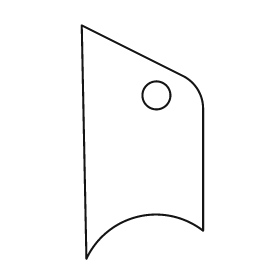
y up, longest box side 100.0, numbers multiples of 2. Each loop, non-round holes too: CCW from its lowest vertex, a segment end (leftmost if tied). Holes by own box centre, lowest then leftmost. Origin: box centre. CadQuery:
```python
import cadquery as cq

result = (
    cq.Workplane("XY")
    .moveTo(-24.0, -50.0)
    .threePointArc((-2.0, -32.0), (26.0, -38.0))
    .lineTo(26.0, 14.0)
    .threePointArc((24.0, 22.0), (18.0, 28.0))
    .lineTo(-26.0, 50.0)
    .close()
    .moveTo(6.0, 20.0)
    .circle(6.0)
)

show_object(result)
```